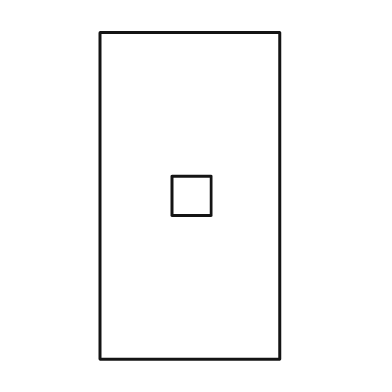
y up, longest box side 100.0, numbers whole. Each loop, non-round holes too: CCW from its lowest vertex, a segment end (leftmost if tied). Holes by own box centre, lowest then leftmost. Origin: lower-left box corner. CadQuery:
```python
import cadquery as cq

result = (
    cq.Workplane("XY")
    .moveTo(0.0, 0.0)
    .lineTo(55.0, 0.0)
    .lineTo(55.0, 100.0)
    .lineTo(0.0, 100.0)
    .close()
    .moveTo(22.0, 44.0)
    .lineTo(34.0, 44.0)
    .lineTo(34.0, 56.0)
    .lineTo(22.0, 56.0)
    .close()
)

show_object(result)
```